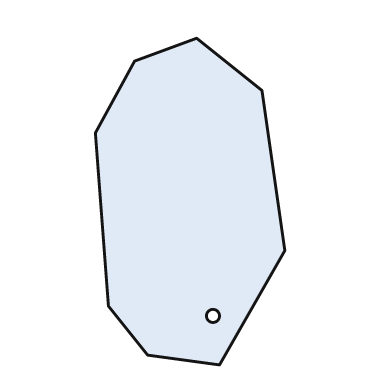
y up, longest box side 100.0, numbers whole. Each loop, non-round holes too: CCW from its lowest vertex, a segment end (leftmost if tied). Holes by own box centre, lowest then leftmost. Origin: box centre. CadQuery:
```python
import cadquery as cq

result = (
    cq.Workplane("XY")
    .moveTo(9.0, -50.0)
    .lineTo(29.0, -15.0)
    .lineTo(22.0, 34.0)
    .lineTo(2.0, 50.0)
    .lineTo(-17.0, 43.0)
    .lineTo(-29.0, 21.0)
    .lineTo(-25.0, -32.0)
    .lineTo(-13.0, -47.0)
    .close()
    .moveTo(7.0, -35.0)
    .circle(2.0)
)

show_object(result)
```